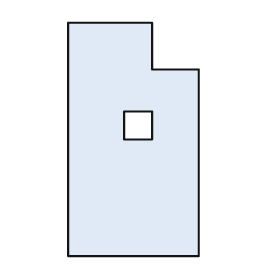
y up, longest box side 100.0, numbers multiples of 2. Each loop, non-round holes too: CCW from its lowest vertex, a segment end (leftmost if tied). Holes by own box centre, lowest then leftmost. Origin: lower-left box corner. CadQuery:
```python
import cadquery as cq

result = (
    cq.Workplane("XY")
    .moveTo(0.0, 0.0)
    .lineTo(56.0, 0.0)
    .lineTo(56.0, 80.0)
    .lineTo(36.0, 80.0)
    .lineTo(36.0, 100.0)
    .lineTo(0.0, 100.0)
    .close()
    .moveTo(24.0, 50.0)
    .lineTo(36.0, 50.0)
    .lineTo(36.0, 62.0)
    .lineTo(24.0, 62.0)
    .close()
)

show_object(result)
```